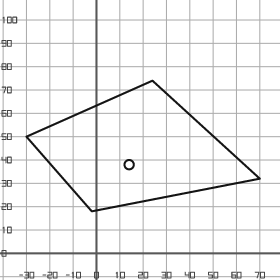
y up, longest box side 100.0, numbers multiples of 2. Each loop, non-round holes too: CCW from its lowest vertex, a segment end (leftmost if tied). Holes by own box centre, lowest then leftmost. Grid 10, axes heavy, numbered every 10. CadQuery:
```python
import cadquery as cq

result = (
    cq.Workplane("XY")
    .moveTo(-2.0, 18.0)
    .lineTo(70.0, 32.0)
    .lineTo(24.0, 74.0)
    .lineTo(-30.0, 50.0)
    .close()
    .moveTo(14.0, 38.0)
    .circle(2.0)
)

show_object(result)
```